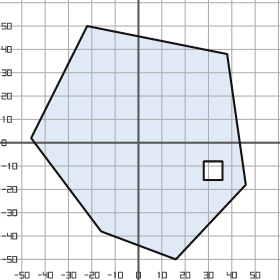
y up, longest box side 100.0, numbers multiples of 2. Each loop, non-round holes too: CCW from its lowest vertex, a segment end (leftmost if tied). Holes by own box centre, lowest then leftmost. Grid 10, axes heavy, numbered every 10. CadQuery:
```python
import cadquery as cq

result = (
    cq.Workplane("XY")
    .moveTo(16.0, -50.0)
    .lineTo(46.0, -18.0)
    .lineTo(38.0, 38.0)
    .lineTo(-22.0, 50.0)
    .lineTo(-46.0, 2.0)
    .lineTo(-16.0, -38.0)
    .close()
    .moveTo(28.0, -16.0)
    .lineTo(36.0, -16.0)
    .lineTo(36.0, -8.0)
    .lineTo(28.0, -8.0)
    .close()
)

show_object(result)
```